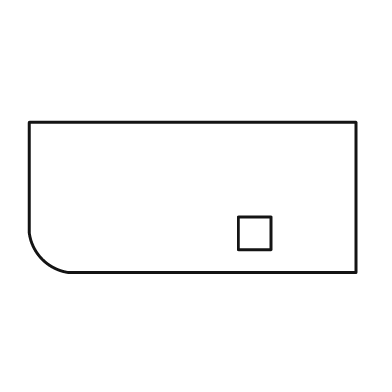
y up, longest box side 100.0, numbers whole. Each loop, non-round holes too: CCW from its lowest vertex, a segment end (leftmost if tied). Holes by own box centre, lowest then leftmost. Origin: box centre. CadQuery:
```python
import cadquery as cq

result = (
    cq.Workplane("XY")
    .moveTo(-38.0, -23.0)
    .lineTo(50.0, -23.0)
    .lineTo(50.0, 23.0)
    .lineTo(-50.0, 23.0)
    .lineTo(-50.0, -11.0)
    .threePointArc((-46.0, -19.0), (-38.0, -23.0))
    .close()
    .moveTo(14.0, -16.0)
    .lineTo(24.0, -16.0)
    .lineTo(24.0, -6.0)
    .lineTo(14.0, -6.0)
    .close()
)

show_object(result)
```